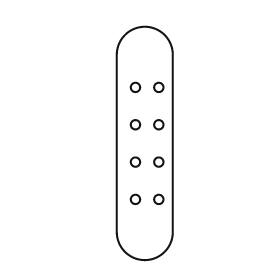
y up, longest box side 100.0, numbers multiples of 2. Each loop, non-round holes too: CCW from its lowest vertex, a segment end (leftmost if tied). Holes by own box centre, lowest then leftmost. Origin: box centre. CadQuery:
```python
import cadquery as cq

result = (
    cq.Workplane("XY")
    .moveTo(-12.0, -38.0)
    .threePointArc((0.0, -50.0), (12.0, -38.0))
    .lineTo(12.0, 38.0)
    .threePointArc((0.0, 50.0), (-12.0, 38.0))
    .close()
    .moveTo(-4.0, -24.0)
    .circle(2.0)
    .moveTo(6.0, -24.0)
    .circle(2.0)
    .moveTo(-4.0, -8.0)
    .circle(2.0)
    .moveTo(6.0, -8.0)
    .circle(2.0)
    .moveTo(-4.0, 8.0)
    .circle(2.0)
    .moveTo(6.0, 8.0)
    .circle(2.0)
    .moveTo(-4.0, 24.0)
    .circle(2.0)
    .moveTo(6.0, 24.0)
    .circle(2.0)
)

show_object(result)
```